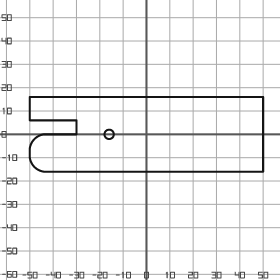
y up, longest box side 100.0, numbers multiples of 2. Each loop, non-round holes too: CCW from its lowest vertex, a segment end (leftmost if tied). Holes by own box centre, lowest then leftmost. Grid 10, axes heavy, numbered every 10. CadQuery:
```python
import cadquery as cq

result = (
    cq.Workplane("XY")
    .moveTo(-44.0, -16.0)
    .lineTo(50.0, -16.0)
    .lineTo(50.0, 16.0)
    .lineTo(-50.0, 16.0)
    .lineTo(-50.0, 6.0)
    .lineTo(-30.0, 6.0)
    .lineTo(-30.0, 0.0)
    .lineTo(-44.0, 0.0)
    .threePointArc((-48.0, -2.0), (-50.0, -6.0))
    .lineTo(-50.0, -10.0)
    .threePointArc((-48.0, -14.0), (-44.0, -16.0))
    .close()
    .moveTo(-16.0, 0.0)
    .circle(2.0)
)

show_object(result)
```